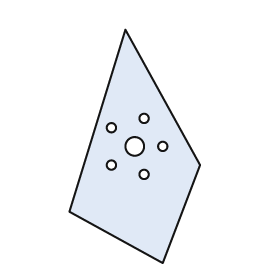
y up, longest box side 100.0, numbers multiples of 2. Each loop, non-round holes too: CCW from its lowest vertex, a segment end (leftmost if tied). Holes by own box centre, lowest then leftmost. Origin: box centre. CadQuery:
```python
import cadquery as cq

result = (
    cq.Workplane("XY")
    .moveTo(12.0, -50.0)
    .lineTo(28.0, -8.0)
    .lineTo(-4.0, 50.0)
    .lineTo(-28.0, -28.0)
    .close()
    .moveTo(4.0, -12.0)
    .circle(2.0)
    .moveTo(-10.0, -8.0)
    .circle(2.0)
    .moveTo(0.0, 0.0)
    .circle(4.0)
    .moveTo(12.0, 0.0)
    .circle(2.0)
    .moveTo(-10.0, 8.0)
    .circle(2.0)
    .moveTo(4.0, 12.0)
    .circle(2.0)
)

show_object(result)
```